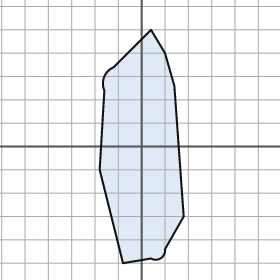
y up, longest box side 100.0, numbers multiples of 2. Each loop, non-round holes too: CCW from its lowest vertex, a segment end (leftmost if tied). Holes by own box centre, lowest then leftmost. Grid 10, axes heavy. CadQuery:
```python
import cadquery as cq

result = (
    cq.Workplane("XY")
    .moveTo(-8.0, -50.0)
    .lineTo(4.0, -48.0)
    .threePointArc((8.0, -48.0), (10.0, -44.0))
    .lineTo(18.0, -30.0)
    .lineTo(14.0, 26.0)
    .lineTo(10.0, 40.0)
    .lineTo(4.0, 50.0)
    .lineTo(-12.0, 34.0)
    .threePointArc((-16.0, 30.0), (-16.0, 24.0))
    .lineTo(-18.0, -10.0)
    .close()
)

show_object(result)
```